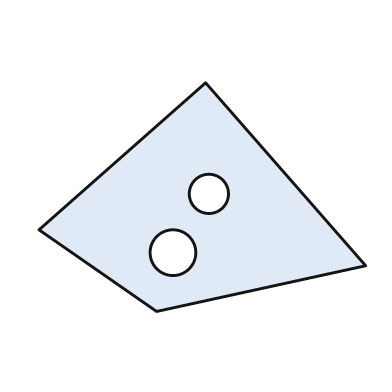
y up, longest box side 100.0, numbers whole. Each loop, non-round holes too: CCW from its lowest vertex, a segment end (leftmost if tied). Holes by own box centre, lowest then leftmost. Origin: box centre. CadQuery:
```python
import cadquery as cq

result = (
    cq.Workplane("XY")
    .moveTo(-14.0, -35.0)
    .lineTo(50.0, -21.0)
    .lineTo(1.0, 35.0)
    .lineTo(-50.0, -10.0)
    .close()
    .moveTo(-9.0, -17.0)
    .circle(7.0)
    .moveTo(2.0, 1.0)
    .circle(6.0)
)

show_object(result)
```